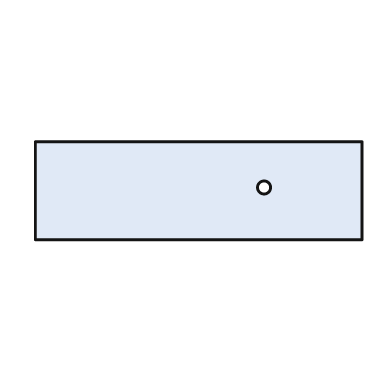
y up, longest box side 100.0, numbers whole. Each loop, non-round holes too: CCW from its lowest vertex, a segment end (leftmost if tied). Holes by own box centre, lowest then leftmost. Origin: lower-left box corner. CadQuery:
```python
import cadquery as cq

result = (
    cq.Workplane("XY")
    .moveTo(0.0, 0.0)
    .lineTo(100.0, 0.0)
    .lineTo(100.0, 30.0)
    .lineTo(0.0, 30.0)
    .close()
    .moveTo(70.0, 16.0)
    .circle(2.0)
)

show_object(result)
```